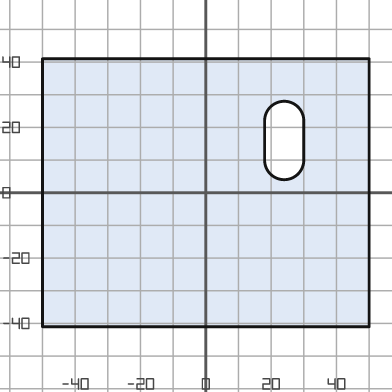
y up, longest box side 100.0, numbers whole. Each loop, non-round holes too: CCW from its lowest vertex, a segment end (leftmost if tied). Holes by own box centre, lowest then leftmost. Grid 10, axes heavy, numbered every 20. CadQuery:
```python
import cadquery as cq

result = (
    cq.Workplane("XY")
    .moveTo(-50.0, -41.0)
    .lineTo(50.0, -41.0)
    .lineTo(50.0, 41.0)
    .lineTo(-50.0, 41.0)
    .close()
    .moveTo(18.0, 10.0)
    .threePointArc((24.0, 4.0), (30.0, 10.0))
    .lineTo(30.0, 22.0)
    .threePointArc((24.0, 28.0), (18.0, 22.0))
    .close()
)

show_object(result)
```